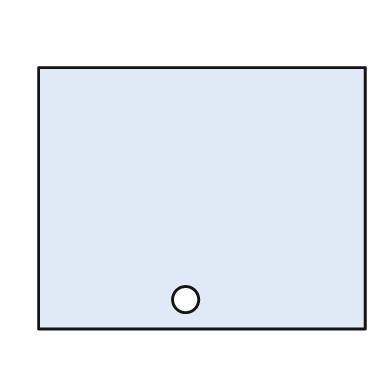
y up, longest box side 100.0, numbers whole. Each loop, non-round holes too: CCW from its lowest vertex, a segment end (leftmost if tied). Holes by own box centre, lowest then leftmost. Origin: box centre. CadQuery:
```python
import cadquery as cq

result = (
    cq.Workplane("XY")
    .moveTo(-50.0, -40.0)
    .lineTo(50.0, -40.0)
    .lineTo(50.0, 40.0)
    .lineTo(-50.0, 40.0)
    .close()
    .moveTo(-5.0, -31.0)
    .circle(4.0)
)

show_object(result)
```